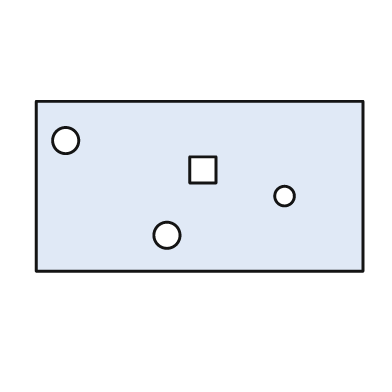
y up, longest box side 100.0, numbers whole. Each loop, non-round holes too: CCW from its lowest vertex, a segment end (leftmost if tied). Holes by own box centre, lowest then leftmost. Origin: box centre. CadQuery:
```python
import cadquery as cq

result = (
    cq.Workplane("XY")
    .moveTo(-50.0, -26.0)
    .lineTo(50.0, -26.0)
    .lineTo(50.0, 26.0)
    .lineTo(-50.0, 26.0)
    .close()
    .moveTo(-10.0, -15.0)
    .circle(4.0)
    .moveTo(26.0, -3.0)
    .circle(3.0)
    .moveTo(-3.0, 1.0)
    .lineTo(5.0, 1.0)
    .lineTo(5.0, 9.0)
    .lineTo(-3.0, 9.0)
    .close()
    .moveTo(-41.0, 14.0)
    .circle(4.0)
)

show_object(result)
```